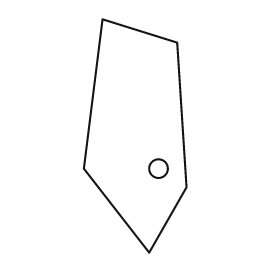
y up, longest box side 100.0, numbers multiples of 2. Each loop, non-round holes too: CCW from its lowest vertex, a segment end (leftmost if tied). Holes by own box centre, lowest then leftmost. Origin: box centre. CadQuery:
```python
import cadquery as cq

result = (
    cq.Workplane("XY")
    .moveTo(6.0, -50.0)
    .lineTo(22.0, -22.0)
    .lineTo(18.0, 40.0)
    .lineTo(-14.0, 50.0)
    .lineTo(-22.0, -14.0)
    .close()
    .moveTo(10.0, -14.0)
    .circle(4.0)
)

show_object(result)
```